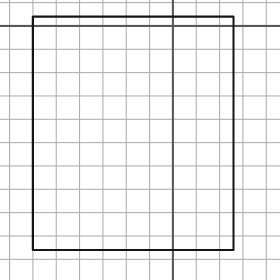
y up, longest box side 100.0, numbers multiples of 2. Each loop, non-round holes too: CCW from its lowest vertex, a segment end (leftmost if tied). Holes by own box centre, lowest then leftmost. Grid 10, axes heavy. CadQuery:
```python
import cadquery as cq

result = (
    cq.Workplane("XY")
    .moveTo(-60.0, -96.0)
    .lineTo(26.0, -96.0)
    .lineTo(26.0, 4.0)
    .lineTo(-60.0, 4.0)
    .close()
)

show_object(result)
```